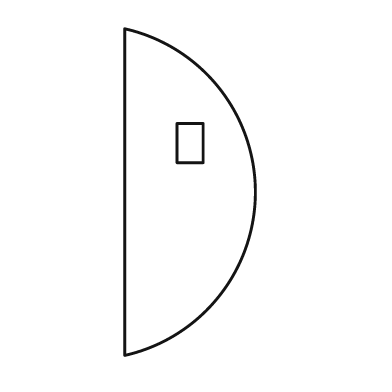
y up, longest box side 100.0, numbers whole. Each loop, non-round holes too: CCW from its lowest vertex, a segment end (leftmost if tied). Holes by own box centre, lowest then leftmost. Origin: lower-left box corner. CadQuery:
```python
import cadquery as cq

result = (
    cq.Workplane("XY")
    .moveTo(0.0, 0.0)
    .threePointArc((40.0, 50.0), (0.0, 100.0))
    .close()
    .moveTo(16.0, 59.0)
    .lineTo(24.0, 59.0)
    .lineTo(24.0, 71.0)
    .lineTo(16.0, 71.0)
    .close()
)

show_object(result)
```